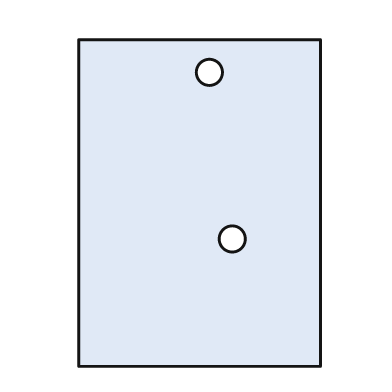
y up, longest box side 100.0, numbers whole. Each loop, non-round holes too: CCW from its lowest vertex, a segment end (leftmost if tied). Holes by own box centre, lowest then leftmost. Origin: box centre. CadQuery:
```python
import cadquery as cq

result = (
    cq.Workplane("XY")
    .moveTo(-37.0, -50.0)
    .lineTo(37.0, -50.0)
    .lineTo(37.0, 50.0)
    .lineTo(-37.0, 50.0)
    .close()
    .moveTo(10.0, -11.0)
    .circle(4.0)
    .moveTo(3.0, 40.0)
    .circle(4.0)
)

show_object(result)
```